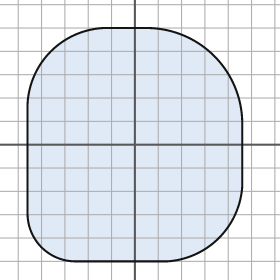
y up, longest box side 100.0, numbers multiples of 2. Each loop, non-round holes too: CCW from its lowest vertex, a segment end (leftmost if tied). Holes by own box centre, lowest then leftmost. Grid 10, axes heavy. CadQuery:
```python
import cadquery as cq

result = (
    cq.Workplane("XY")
    .moveTo(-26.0, -50.0)
    .lineTo(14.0, -50.0)
    .threePointArc((36.0, -40.0), (46.0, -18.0))
    .lineTo(46.0, 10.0)
    .threePointArc((34.0, 38.0), (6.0, 50.0))
    .lineTo(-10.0, 50.0)
    .threePointArc((-36.0, 40.0), (-46.0, 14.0))
    .lineTo(-46.0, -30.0)
    .threePointArc((-40.0, -44.0), (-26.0, -50.0))
    .close()
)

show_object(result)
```